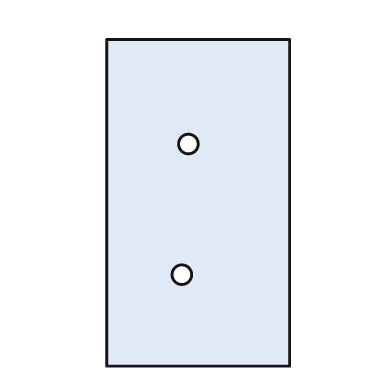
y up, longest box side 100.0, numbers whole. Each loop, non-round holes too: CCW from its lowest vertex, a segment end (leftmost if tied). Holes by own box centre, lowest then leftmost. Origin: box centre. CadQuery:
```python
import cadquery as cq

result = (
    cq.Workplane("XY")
    .moveTo(-28.0, -50.0)
    .lineTo(28.0, -50.0)
    .lineTo(28.0, 50.0)
    .lineTo(-28.0, 50.0)
    .close()
    .moveTo(-5.0, -22.0)
    .circle(3.0)
    .moveTo(-3.0, 18.0)
    .circle(3.0)
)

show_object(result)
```